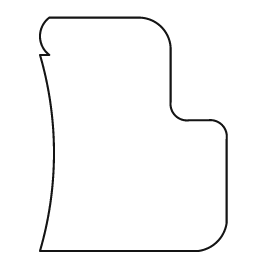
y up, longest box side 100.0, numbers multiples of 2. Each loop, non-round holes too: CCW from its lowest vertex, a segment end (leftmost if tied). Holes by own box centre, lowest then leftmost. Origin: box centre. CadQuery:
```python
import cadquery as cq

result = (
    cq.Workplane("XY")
    .moveTo(-40.0, -50.0)
    .lineTo(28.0, -50.0)
    .threePointArc((36.0, -46.0), (40.0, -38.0))
    .lineTo(40.0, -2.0)
    .threePointArc((38.0, 4.0), (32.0, 6.0))
    .lineTo(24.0, 6.0)
    .threePointArc((18.0, 8.0), (16.0, 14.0))
    .lineTo(16.0, 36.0)
    .threePointArc((12.0, 46.0), (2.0, 50.0))
    .lineTo(-36.0, 50.0)
    .threePointArc((-40.0, 42.0), (-36.0, 34.0))
    .lineTo(-40.0, 34.0)
    .threePointArc((-34.0, -8.0), (-40.0, -50.0))
    .close()
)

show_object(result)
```